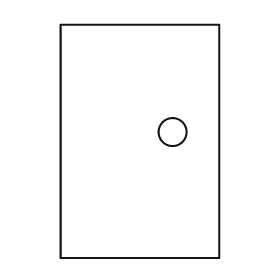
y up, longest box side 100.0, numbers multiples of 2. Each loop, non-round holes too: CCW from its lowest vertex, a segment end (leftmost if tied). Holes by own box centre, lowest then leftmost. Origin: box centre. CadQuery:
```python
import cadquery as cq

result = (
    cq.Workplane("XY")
    .moveTo(-34.0, -50.0)
    .lineTo(34.0, -50.0)
    .lineTo(34.0, 50.0)
    .lineTo(-34.0, 50.0)
    .close()
    .moveTo(14.0, 4.0)
    .circle(6.0)
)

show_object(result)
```